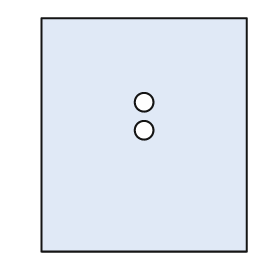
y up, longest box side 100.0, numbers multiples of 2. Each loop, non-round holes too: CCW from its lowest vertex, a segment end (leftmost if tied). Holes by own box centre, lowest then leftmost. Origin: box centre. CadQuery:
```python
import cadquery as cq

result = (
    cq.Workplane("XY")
    .moveTo(-44.0, -50.0)
    .lineTo(44.0, -50.0)
    .lineTo(44.0, 50.0)
    .lineTo(-44.0, 50.0)
    .close()
    .moveTo(0.0, 2.0)
    .circle(4.0)
    .moveTo(0.0, 14.0)
    .circle(4.0)
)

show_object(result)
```